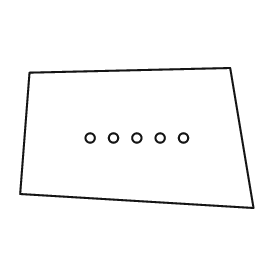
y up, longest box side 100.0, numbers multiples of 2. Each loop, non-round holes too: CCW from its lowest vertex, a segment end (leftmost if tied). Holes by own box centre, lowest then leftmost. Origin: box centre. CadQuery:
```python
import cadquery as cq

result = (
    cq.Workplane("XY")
    .moveTo(50.0, -30.0)
    .lineTo(40.0, 30.0)
    .lineTo(-46.0, 28.0)
    .lineTo(-50.0, -24.0)
    .close()
    .moveTo(-20.0, 0.0)
    .circle(2.0)
    .moveTo(-10.0, 0.0)
    .circle(2.0)
    .moveTo(0.0, 0.0)
    .circle(2.0)
    .moveTo(10.0, 0.0)
    .circle(2.0)
    .moveTo(20.0, 0.0)
    .circle(2.0)
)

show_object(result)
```